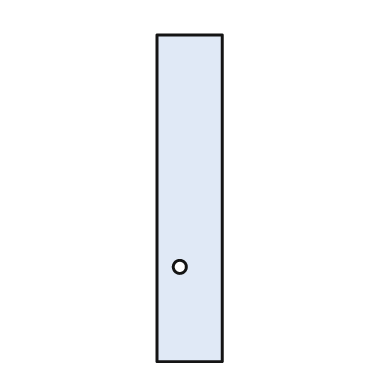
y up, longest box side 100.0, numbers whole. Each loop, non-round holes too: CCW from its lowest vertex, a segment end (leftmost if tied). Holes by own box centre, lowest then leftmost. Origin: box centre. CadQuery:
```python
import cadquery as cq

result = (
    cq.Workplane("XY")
    .moveTo(-10.0, -50.0)
    .lineTo(10.0, -50.0)
    .lineTo(10.0, 50.0)
    .lineTo(-10.0, 50.0)
    .close()
    .moveTo(-3.0, -21.0)
    .circle(2.0)
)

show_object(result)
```